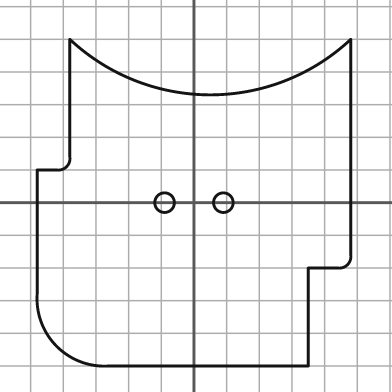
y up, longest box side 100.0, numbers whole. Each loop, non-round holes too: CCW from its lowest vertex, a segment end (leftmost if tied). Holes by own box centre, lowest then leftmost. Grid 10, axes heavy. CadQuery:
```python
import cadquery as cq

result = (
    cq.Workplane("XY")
    .moveTo(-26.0, -50.0)
    .lineTo(35.0, -50.0)
    .lineTo(35.0, -20.0)
    .lineTo(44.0, -20.0)
    .threePointArc((47.0, -19.0), (48.0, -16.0))
    .lineTo(48.0, 50.0)
    .threePointArc((5.0, 33.0), (-38.0, 50.0))
    .lineTo(-38.0, 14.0)
    .threePointArc((-39.0, 11.0), (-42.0, 10.0))
    .lineTo(-48.0, 10.0)
    .lineTo(-48.0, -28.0)
    .threePointArc((-42.0, -44.0), (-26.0, -50.0))
    .close()
    .moveTo(-9.0, 0.0)
    .circle(3.0)
    .moveTo(9.0, 0.0)
    .circle(3.0)
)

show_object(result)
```